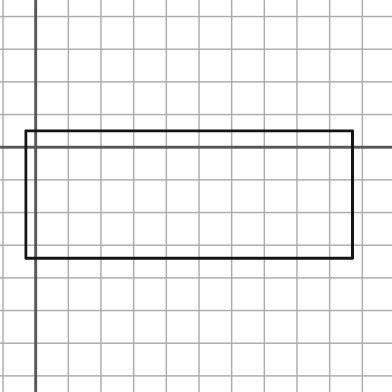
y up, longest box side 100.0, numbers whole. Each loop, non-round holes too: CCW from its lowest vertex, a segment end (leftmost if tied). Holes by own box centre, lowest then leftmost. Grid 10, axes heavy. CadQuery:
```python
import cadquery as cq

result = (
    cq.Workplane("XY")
    .moveTo(-3.0, -34.0)
    .lineTo(97.0, -34.0)
    .lineTo(97.0, 5.0)
    .lineTo(-3.0, 5.0)
    .close()
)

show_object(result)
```